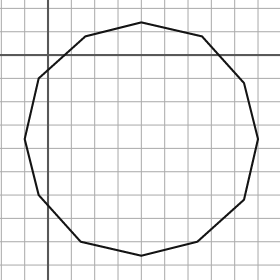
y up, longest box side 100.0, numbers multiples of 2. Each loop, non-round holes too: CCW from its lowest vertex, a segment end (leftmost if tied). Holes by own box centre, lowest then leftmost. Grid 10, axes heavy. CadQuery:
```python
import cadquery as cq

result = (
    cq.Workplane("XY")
    .moveTo(40.0, -86.0)
    .lineTo(64.0, -80.0)
    .lineTo(84.0, -62.0)
    .lineTo(90.0, -36.0)
    .lineTo(84.0, -12.0)
    .lineTo(66.0, 8.0)
    .lineTo(40.0, 14.0)
    .lineTo(16.0, 8.0)
    .lineTo(-4.0, -10.0)
    .lineTo(-10.0, -36.0)
    .lineTo(-4.0, -60.0)
    .lineTo(14.0, -80.0)
    .close()
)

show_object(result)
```